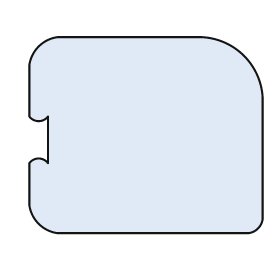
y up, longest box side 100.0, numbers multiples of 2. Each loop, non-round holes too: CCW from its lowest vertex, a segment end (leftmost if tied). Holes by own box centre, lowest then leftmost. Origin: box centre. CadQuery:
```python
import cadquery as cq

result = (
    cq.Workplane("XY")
    .moveTo(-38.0, -42.0)
    .lineTo(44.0, -42.0)
    .threePointArc((48.0, -40.0), (50.0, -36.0))
    .lineTo(50.0, 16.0)
    .threePointArc((42.0, 34.0), (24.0, 42.0))
    .lineTo(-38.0, 42.0)
    .threePointArc((-46.0, 38.0), (-50.0, 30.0))
    .lineTo(-50.0, 8.0)
    .threePointArc((-46.0, 6.0), (-42.0, 8.0))
    .lineTo(-42.0, -12.0)
    .threePointArc((-46.0, -10.0), (-50.0, -12.0))
    .lineTo(-50.0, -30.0)
    .threePointArc((-46.0, -38.0), (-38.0, -42.0))
    .close()
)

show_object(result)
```